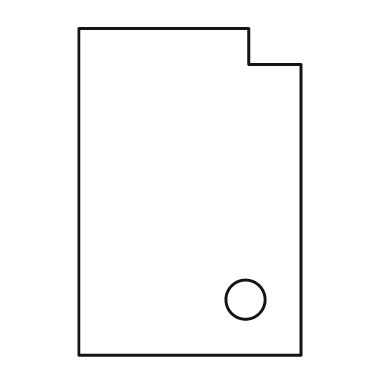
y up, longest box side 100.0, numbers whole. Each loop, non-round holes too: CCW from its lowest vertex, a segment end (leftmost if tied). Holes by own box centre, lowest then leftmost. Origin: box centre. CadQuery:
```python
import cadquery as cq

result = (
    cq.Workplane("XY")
    .moveTo(-34.0, -50.0)
    .lineTo(34.0, -50.0)
    .lineTo(34.0, 39.0)
    .lineTo(18.0, 39.0)
    .lineTo(18.0, 50.0)
    .lineTo(-34.0, 50.0)
    .close()
    .moveTo(17.0, -33.0)
    .circle(6.0)
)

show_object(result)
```